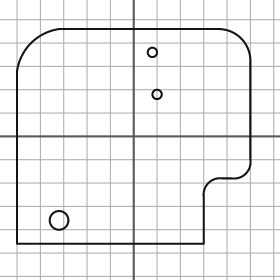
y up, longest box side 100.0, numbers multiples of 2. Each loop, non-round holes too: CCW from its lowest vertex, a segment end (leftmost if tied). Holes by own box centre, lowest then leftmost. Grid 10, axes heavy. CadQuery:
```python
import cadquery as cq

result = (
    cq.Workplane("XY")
    .moveTo(-50.0, -46.0)
    .lineTo(30.0, -46.0)
    .lineTo(30.0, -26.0)
    .threePointArc((32.0, -20.0), (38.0, -18.0))
    .lineTo(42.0, -18.0)
    .threePointArc((48.0, -16.0), (50.0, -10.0))
    .lineTo(50.0, 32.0)
    .threePointArc((46.0, 42.0), (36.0, 46.0))
    .lineTo(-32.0, 46.0)
    .threePointArc((-44.0, 40.0), (-50.0, 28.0))
    .close()
    .moveTo(-32.0, -36.0)
    .circle(4.0)
    .moveTo(10.0, 18.0)
    .circle(2.0)
    .moveTo(8.0, 36.0)
    .circle(2.0)
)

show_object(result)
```